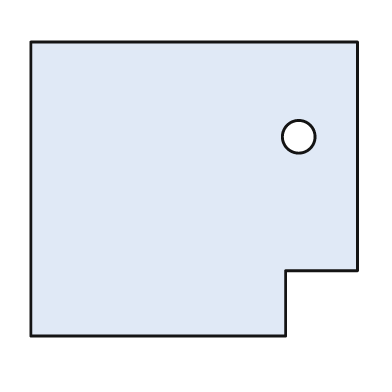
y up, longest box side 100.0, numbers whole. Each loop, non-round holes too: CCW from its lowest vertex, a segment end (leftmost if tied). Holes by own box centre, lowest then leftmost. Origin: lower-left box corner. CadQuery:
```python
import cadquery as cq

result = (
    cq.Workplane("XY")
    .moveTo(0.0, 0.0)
    .lineTo(78.0, 0.0)
    .lineTo(78.0, 20.0)
    .lineTo(100.0, 20.0)
    .lineTo(100.0, 90.0)
    .lineTo(0.0, 90.0)
    .close()
    .moveTo(82.0, 61.0)
    .circle(5.0)
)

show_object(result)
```